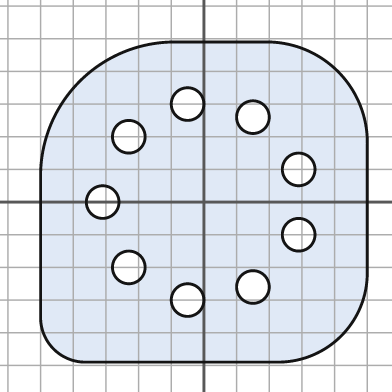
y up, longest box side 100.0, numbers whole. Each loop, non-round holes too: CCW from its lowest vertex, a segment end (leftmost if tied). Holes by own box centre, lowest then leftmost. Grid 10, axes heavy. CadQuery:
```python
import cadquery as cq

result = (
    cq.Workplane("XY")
    .moveTo(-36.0, -49.0)
    .lineTo(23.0, -49.0)
    .threePointArc((42.0, -41.0), (50.0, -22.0))
    .lineTo(50.0, 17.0)
    .threePointArc((41.0, 40.0), (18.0, 49.0))
    .lineTo(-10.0, 49.0)
    .threePointArc((-38.0, 37.0), (-50.0, 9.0))
    .lineTo(-50.0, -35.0)
    .threePointArc((-46.0, -45.0), (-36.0, -49.0))
    .close()
    .moveTo(-5.0, -30.0)
    .circle(5.0)
    .moveTo(15.0, -26.0)
    .circle(5.0)
    .moveTo(-23.0, -20.0)
    .circle(5.0)
    .moveTo(29.0, -10.0)
    .circle(5.0)
    .moveTo(-31.0, 0.0)
    .circle(5.0)
    .moveTo(29.0, 10.0)
    .circle(5.0)
    .moveTo(-23.0, 20.0)
    .circle(5.0)
    .moveTo(15.0, 26.0)
    .circle(5.0)
    .moveTo(-5.0, 30.0)
    .circle(5.0)
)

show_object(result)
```